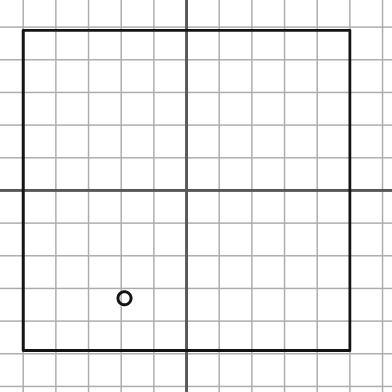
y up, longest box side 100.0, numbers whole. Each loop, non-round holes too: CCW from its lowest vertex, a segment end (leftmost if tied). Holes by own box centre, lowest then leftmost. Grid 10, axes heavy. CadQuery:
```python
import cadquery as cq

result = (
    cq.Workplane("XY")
    .moveTo(-50.0, -49.0)
    .lineTo(50.0, -49.0)
    .lineTo(50.0, 49.0)
    .lineTo(-50.0, 49.0)
    .close()
    .moveTo(-19.0, -33.0)
    .circle(2.0)
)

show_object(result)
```